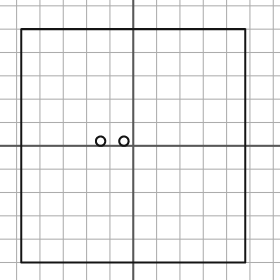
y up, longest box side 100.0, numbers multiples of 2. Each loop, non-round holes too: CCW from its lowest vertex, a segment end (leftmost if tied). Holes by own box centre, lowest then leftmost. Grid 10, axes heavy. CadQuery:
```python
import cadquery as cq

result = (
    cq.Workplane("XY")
    .moveTo(-48.0, -50.0)
    .lineTo(48.0, -50.0)
    .lineTo(48.0, 50.0)
    .lineTo(-48.0, 50.0)
    .close()
    .moveTo(-14.0, 2.0)
    .circle(2.0)
    .moveTo(-4.0, 2.0)
    .circle(2.0)
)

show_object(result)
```